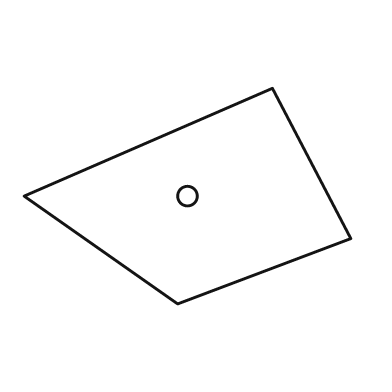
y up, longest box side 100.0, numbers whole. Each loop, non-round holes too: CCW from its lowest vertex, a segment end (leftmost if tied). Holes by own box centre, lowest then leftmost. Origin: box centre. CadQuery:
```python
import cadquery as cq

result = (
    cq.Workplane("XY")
    .moveTo(-3.0, -33.0)
    .lineTo(50.0, -13.0)
    .lineTo(26.0, 33.0)
    .lineTo(-50.0, 0.0)
    .close()
    .moveTo(0.0, 0.0)
    .circle(3.0)
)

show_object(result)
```